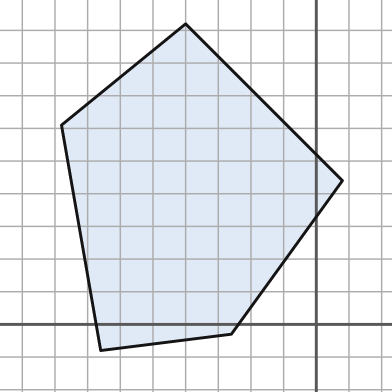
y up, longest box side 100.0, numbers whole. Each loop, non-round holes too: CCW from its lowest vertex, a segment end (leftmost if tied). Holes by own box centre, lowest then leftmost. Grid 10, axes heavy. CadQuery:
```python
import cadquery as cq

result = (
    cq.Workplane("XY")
    .moveTo(-66.0, -8.0)
    .lineTo(-26.0, -3.0)
    .lineTo(8.0, 44.0)
    .lineTo(-40.0, 92.0)
    .lineTo(-78.0, 61.0)
    .close()
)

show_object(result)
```